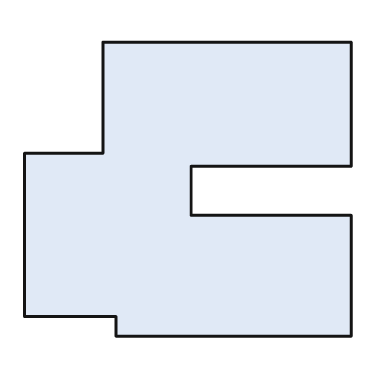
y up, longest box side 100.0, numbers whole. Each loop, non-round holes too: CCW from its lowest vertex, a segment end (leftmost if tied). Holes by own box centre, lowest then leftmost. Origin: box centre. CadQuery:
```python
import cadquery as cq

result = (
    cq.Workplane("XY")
    .moveTo(-22.0, -45.0)
    .lineTo(50.0, -45.0)
    .lineTo(50.0, -8.0)
    .lineTo(1.0, -8.0)
    .lineTo(1.0, 7.0)
    .lineTo(50.0, 7.0)
    .lineTo(50.0, 45.0)
    .lineTo(-26.0, 45.0)
    .lineTo(-26.0, 11.0)
    .lineTo(-50.0, 11.0)
    .lineTo(-50.0, -39.0)
    .lineTo(-22.0, -39.0)
    .close()
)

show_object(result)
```